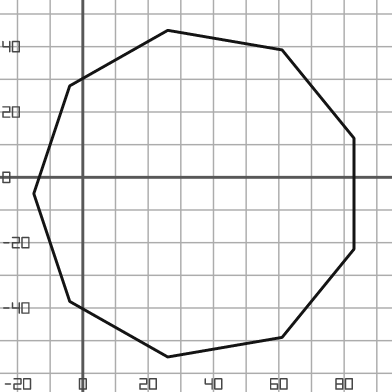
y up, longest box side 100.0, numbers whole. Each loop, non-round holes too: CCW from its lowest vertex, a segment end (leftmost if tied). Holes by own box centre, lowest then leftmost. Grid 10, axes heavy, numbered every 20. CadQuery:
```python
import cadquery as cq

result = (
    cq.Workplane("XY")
    .moveTo(26.0, -55.0)
    .lineTo(61.0, -49.0)
    .lineTo(83.0, -22.0)
    .lineTo(83.0, 12.0)
    .lineTo(61.0, 39.0)
    .lineTo(26.0, 45.0)
    .lineTo(-4.0, 28.0)
    .lineTo(-15.0, -5.0)
    .lineTo(-4.0, -38.0)
    .close()
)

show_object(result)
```